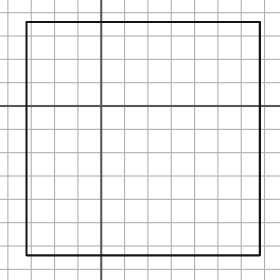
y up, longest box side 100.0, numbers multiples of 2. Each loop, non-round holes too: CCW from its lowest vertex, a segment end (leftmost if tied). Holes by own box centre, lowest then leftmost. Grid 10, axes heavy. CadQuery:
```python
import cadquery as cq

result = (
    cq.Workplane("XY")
    .moveTo(-32.0, -64.0)
    .lineTo(68.0, -64.0)
    .lineTo(68.0, 36.0)
    .lineTo(-32.0, 36.0)
    .close()
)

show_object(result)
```